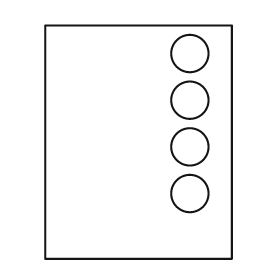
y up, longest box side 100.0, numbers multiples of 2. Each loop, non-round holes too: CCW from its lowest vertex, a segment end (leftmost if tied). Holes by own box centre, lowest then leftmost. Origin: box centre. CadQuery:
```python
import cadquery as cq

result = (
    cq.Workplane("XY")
    .moveTo(-40.0, -50.0)
    .lineTo(40.0, -50.0)
    .lineTo(40.0, 50.0)
    .lineTo(-40.0, 50.0)
    .close()
    .moveTo(22.0, -22.0)
    .circle(8.0)
    .moveTo(22.0, -2.0)
    .circle(8.0)
    .moveTo(22.0, 18.0)
    .circle(8.0)
    .moveTo(22.0, 38.0)
    .circle(8.0)
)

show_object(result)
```